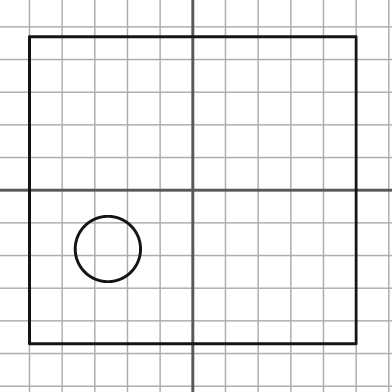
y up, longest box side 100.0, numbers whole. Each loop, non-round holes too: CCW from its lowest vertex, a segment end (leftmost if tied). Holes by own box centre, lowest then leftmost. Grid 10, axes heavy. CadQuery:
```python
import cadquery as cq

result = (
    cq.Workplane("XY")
    .moveTo(-50.0, -47.0)
    .lineTo(50.0, -47.0)
    .lineTo(50.0, 47.0)
    .lineTo(-50.0, 47.0)
    .close()
    .moveTo(-26.0, -18.0)
    .circle(10.0)
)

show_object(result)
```